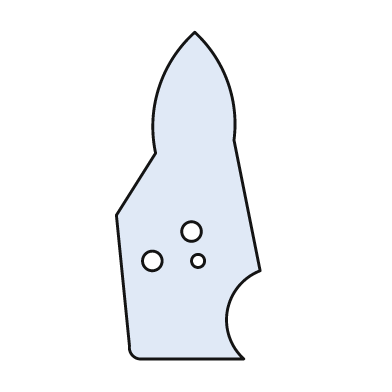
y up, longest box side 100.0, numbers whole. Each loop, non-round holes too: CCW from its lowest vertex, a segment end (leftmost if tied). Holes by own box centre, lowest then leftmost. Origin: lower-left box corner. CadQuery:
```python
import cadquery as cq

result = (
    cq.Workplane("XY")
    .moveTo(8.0, 0.0)
    .lineTo(39.0, 0.0)
    .threePointArc((34.0, 15.0), (44.0, 27.0))
    .lineTo(36.0, 67.0)
    .threePointArc((34.0, 85.0), (24.0, 100.0))
    .threePointArc((13.0, 83.0), (12.0, 63.0))
    .lineTo(0.0, 44.0)
    .lineTo(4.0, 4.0)
    .threePointArc((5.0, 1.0), (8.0, 0.0))
    .close()
    .moveTo(11.0, 30.0)
    .circle(3.0)
    .moveTo(25.0, 30.0)
    .circle(2.0)
    .moveTo(23.0, 39.0)
    .circle(3.0)
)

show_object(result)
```